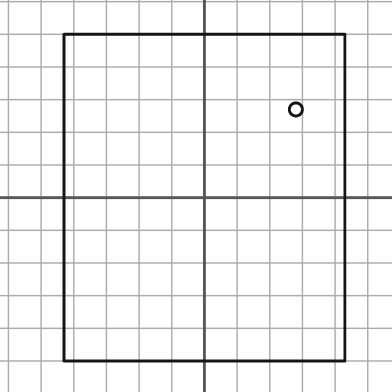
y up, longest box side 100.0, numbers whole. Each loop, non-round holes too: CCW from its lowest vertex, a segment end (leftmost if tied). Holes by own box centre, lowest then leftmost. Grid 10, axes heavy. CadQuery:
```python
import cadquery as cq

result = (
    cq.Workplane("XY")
    .moveTo(-43.0, -50.0)
    .lineTo(43.0, -50.0)
    .lineTo(43.0, 50.0)
    .lineTo(-43.0, 50.0)
    .close()
    .moveTo(28.0, 27.0)
    .circle(2.0)
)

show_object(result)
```